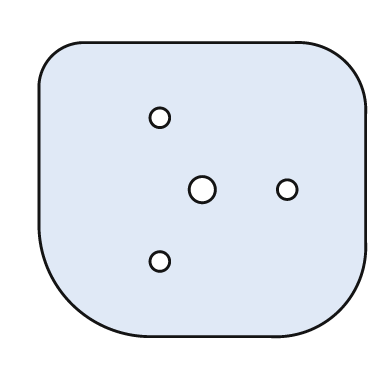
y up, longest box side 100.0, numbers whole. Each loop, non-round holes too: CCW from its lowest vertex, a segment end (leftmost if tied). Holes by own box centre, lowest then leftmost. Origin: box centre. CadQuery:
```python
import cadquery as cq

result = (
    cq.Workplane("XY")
    .moveTo(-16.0, -45.0)
    .lineTo(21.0, -45.0)
    .threePointArc((42.0, -37.0), (50.0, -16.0))
    .lineTo(50.0, 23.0)
    .threePointArc((44.0, 39.0), (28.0, 45.0))
    .lineTo(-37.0, 45.0)
    .threePointArc((-46.0, 41.0), (-50.0, 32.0))
    .lineTo(-50.0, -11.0)
    .threePointArc((-40.0, -35.0), (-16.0, -45.0))
    .close()
    .moveTo(-13.0, -22.0)
    .circle(3.0)
    .moveTo(0.0, 0.0)
    .circle(4.0)
    .moveTo(26.0, 0.0)
    .circle(3.0)
    .moveTo(-13.0, 22.0)
    .circle(3.0)
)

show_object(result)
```